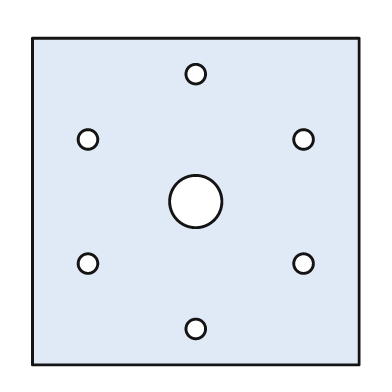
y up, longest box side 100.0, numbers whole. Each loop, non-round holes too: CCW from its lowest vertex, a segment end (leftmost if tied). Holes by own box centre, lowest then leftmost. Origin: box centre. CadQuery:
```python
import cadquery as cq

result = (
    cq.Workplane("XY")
    .moveTo(-50.0, -50.0)
    .lineTo(50.0, -50.0)
    .lineTo(50.0, 50.0)
    .lineTo(-50.0, 50.0)
    .close()
    .moveTo(0.0, -39.0)
    .circle(3.0)
    .moveTo(-33.0, -19.0)
    .circle(3.0)
    .moveTo(33.0, -19.0)
    .circle(3.0)
    .moveTo(0.0, 0.0)
    .circle(8.0)
    .moveTo(-33.0, 19.0)
    .circle(3.0)
    .moveTo(33.0, 19.0)
    .circle(3.0)
    .moveTo(0.0, 39.0)
    .circle(3.0)
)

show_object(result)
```